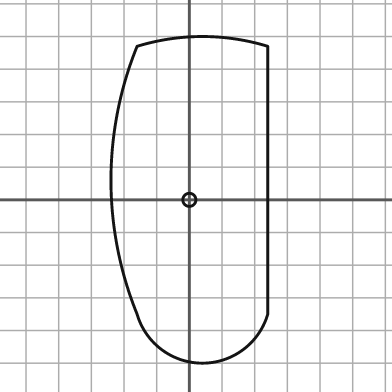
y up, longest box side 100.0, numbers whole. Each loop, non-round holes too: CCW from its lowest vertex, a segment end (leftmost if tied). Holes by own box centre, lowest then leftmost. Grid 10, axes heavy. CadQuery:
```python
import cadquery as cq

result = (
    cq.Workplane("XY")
    .moveTo(-16.0, -35.0)
    .threePointArc((4.0, -50.0), (24.0, -35.0))
    .lineTo(24.0, 47.0)
    .threePointArc((4.0, 50.0), (-16.0, 47.0))
    .threePointArc((-24.0, 6.0), (-16.0, -35.0))
    .close()
    .moveTo(0.0, 0.0)
    .circle(2.0)
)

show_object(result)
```